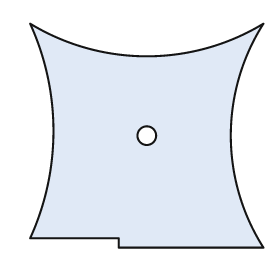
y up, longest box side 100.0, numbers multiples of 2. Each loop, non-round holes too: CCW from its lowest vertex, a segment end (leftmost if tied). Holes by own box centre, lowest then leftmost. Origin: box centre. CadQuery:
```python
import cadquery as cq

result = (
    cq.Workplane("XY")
    .moveTo(-12.0, -48.0)
    .lineTo(50.0, -48.0)
    .threePointArc((36.0, 0.0), (50.0, 48.0))
    .threePointArc((0.0, 34.0), (-50.0, 48.0))
    .threePointArc((-40.0, 2.0), (-50.0, -44.0))
    .lineTo(-12.0, -44.0)
    .close()
    .moveTo(0.0, 0.0)
    .circle(4.0)
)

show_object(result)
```